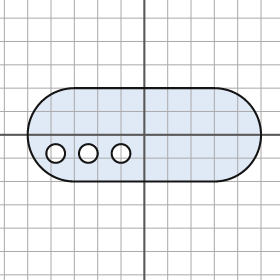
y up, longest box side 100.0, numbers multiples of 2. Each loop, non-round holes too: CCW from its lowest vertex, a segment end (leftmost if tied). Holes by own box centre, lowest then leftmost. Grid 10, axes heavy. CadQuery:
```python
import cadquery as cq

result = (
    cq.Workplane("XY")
    .moveTo(-30.0, -20.0)
    .lineTo(30.0, -20.0)
    .threePointArc((50.0, 0.0), (30.0, 20.0))
    .lineTo(-30.0, 20.0)
    .threePointArc((-50.0, 0.0), (-30.0, -20.0))
    .close()
    .moveTo(-38.0, -8.0)
    .circle(4.0)
    .moveTo(-24.0, -8.0)
    .circle(4.0)
    .moveTo(-10.0, -8.0)
    .circle(4.0)
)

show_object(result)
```